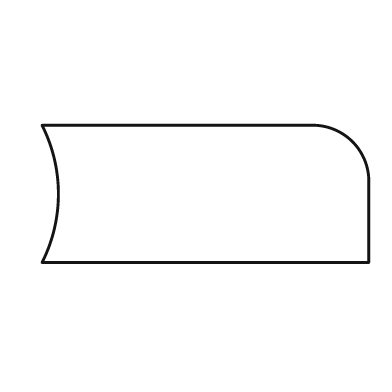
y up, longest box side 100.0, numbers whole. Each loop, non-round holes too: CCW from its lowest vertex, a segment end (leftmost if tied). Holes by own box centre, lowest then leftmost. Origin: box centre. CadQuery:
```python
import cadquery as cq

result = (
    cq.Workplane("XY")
    .moveTo(-50.0, -21.0)
    .lineTo(50.0, -21.0)
    .lineTo(50.0, 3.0)
    .threePointArc((45.0, 16.0), (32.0, 21.0))
    .lineTo(-50.0, 21.0)
    .threePointArc((-45.0, 0.0), (-50.0, -21.0))
    .close()
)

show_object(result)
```